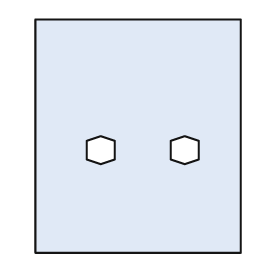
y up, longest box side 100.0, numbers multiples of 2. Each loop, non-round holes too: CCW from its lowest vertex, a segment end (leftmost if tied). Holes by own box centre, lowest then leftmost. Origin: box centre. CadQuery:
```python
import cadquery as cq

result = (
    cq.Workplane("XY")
    .moveTo(-44.0, -50.0)
    .lineTo(44.0, -50.0)
    .lineTo(44.0, 50.0)
    .lineTo(-44.0, 50.0)
    .close()
    .moveTo(-16.0, -12.0)
    .lineTo(-10.0, -10.0)
    .lineTo(-10.0, -2.0)
    .lineTo(-16.0, 0.0)
    .lineTo(-22.0, -2.0)
    .lineTo(-22.0, -10.0)
    .close()
    .moveTo(20.0, -12.0)
    .lineTo(26.0, -10.0)
    .lineTo(26.0, -2.0)
    .lineTo(20.0, 0.0)
    .lineTo(14.0, -2.0)
    .lineTo(14.0, -10.0)
    .close()
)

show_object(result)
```